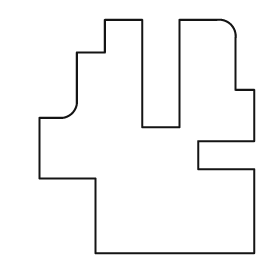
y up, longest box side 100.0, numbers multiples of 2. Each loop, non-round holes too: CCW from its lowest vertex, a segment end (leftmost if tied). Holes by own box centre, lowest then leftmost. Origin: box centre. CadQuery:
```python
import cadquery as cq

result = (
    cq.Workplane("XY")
    .moveTo(-22.0, -50.0)
    .lineTo(46.0, -50.0)
    .lineTo(46.0, -14.0)
    .lineTo(22.0, -14.0)
    .lineTo(22.0, -2.0)
    .lineTo(46.0, -2.0)
    .lineTo(46.0, 20.0)
    .lineTo(38.0, 20.0)
    .lineTo(38.0, 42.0)
    .threePointArc((36.0, 48.0), (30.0, 50.0))
    .lineTo(14.0, 50.0)
    .lineTo(14.0, 4.0)
    .lineTo(-2.0, 4.0)
    .lineTo(-2.0, 50.0)
    .lineTo(-18.0, 50.0)
    .lineTo(-18.0, 36.0)
    .lineTo(-30.0, 36.0)
    .lineTo(-30.0, 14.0)
    .threePointArc((-32.0, 10.0), (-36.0, 8.0))
    .lineTo(-46.0, 8.0)
    .lineTo(-46.0, -18.0)
    .lineTo(-22.0, -18.0)
    .close()
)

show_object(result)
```